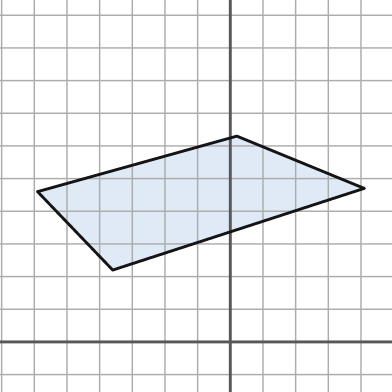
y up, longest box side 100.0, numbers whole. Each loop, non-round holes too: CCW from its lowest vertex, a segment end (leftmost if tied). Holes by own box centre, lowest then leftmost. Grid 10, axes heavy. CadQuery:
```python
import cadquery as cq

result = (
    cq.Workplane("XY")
    .moveTo(-36.0, 22.0)
    .lineTo(41.0, 47.0)
    .lineTo(2.0, 63.0)
    .lineTo(-59.0, 46.0)
    .close()
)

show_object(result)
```